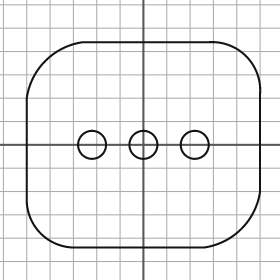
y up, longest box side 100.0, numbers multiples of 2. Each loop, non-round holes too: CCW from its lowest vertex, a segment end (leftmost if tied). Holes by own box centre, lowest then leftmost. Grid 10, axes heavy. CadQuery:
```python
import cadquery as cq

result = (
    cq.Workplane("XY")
    .moveTo(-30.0, -44.0)
    .lineTo(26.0, -44.0)
    .threePointArc((42.0, -36.0), (50.0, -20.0))
    .lineTo(50.0, 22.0)
    .threePointArc((44.0, 38.0), (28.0, 44.0))
    .lineTo(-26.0, 44.0)
    .threePointArc((-42.0, 36.0), (-50.0, 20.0))
    .lineTo(-50.0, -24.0)
    .threePointArc((-44.0, -38.0), (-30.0, -44.0))
    .close()
    .moveTo(-22.0, 0.0)
    .circle(6.0)
    .moveTo(0.0, 0.0)
    .circle(6.0)
    .moveTo(22.0, 0.0)
    .circle(6.0)
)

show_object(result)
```